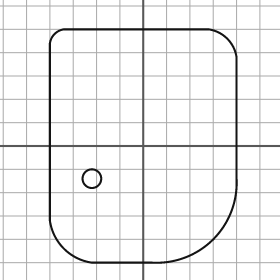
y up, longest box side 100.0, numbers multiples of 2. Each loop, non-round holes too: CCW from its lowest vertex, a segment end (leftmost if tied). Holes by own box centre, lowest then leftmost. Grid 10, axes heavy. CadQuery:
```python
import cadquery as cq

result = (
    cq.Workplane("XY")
    .moveTo(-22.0, -50.0)
    .lineTo(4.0, -50.0)
    .threePointArc((30.0, -40.0), (40.0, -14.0))
    .lineTo(40.0, 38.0)
    .threePointArc((36.0, 46.0), (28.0, 50.0))
    .lineTo(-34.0, 50.0)
    .threePointArc((-38.0, 48.0), (-40.0, 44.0))
    .lineTo(-40.0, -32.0)
    .threePointArc((-34.0, -44.0), (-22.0, -50.0))
    .close()
    .moveTo(-22.0, -14.0)
    .circle(4.0)
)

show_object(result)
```